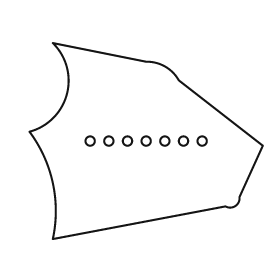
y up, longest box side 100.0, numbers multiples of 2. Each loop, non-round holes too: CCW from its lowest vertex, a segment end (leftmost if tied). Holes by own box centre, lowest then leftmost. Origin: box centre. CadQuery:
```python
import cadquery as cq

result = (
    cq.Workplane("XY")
    .moveTo(-40.0, -42.0)
    .lineTo(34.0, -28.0)
    .threePointArc((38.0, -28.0), (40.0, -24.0))
    .lineTo(50.0, -2.0)
    .lineTo(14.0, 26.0)
    .threePointArc((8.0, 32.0), (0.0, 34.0))
    .lineTo(-40.0, 42.0)
    .threePointArc((-34.0, 20.0), (-50.0, 4.0))
    .threePointArc((-40.0, -18.0), (-40.0, -42.0))
    .close()
    .moveTo(-24.0, 0.0)
    .circle(2.0)
    .moveTo(-16.0, 0.0)
    .circle(2.0)
    .moveTo(-8.0, 0.0)
    .circle(2.0)
    .moveTo(0.0, 0.0)
    .circle(2.0)
    .moveTo(8.0, 0.0)
    .circle(2.0)
    .moveTo(16.0, 0.0)
    .circle(2.0)
    .moveTo(24.0, 0.0)
    .circle(2.0)
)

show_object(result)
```